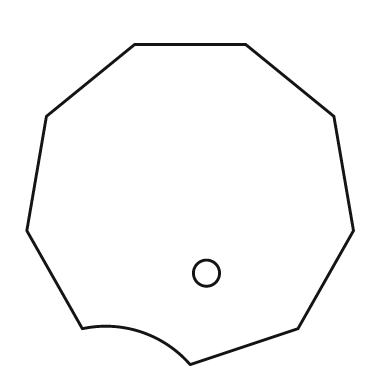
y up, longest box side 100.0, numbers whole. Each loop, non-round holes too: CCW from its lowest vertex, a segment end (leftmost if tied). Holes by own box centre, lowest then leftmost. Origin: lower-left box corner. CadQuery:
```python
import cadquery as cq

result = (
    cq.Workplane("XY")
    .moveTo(50.0, 0.0)
    .lineTo(83.0, 11.0)
    .lineTo(100.0, 41.0)
    .lineTo(94.0, 76.0)
    .lineTo(67.0, 98.0)
    .lineTo(33.0, 98.0)
    .lineTo(6.0, 76.0)
    .lineTo(0.0, 41.0)
    .lineTo(17.0, 11.0)
    .threePointArc((35.0, 10.0), (50.0, 0.0))
    .close()
    .moveTo(55.0, 28.0)
    .circle(4.0)
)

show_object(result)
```